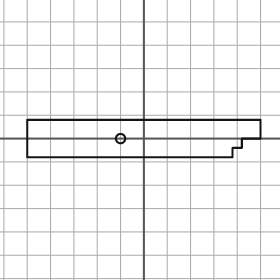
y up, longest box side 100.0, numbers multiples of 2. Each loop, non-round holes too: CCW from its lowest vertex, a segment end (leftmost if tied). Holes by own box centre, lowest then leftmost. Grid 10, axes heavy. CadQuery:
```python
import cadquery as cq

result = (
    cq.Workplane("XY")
    .moveTo(-50.0, -8.0)
    .lineTo(38.0, -8.0)
    .lineTo(38.0, -4.0)
    .lineTo(42.0, -4.0)
    .lineTo(42.0, 0.0)
    .lineTo(50.0, 0.0)
    .lineTo(50.0, 8.0)
    .lineTo(-50.0, 8.0)
    .close()
    .moveTo(-10.0, 0.0)
    .circle(2.0)
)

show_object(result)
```